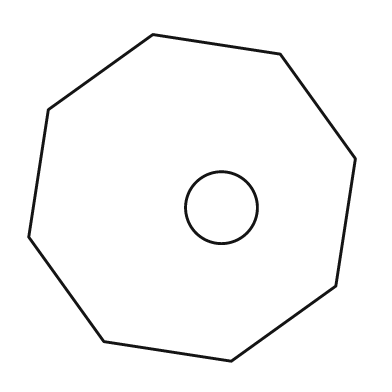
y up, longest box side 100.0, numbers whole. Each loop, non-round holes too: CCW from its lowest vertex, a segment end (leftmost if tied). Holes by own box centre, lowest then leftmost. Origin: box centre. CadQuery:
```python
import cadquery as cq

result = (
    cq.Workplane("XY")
    .moveTo(12.0, -50.0)
    .lineTo(44.0, -27.0)
    .lineTo(50.0, 12.0)
    .lineTo(27.0, 44.0)
    .lineTo(-12.0, 50.0)
    .lineTo(-44.0, 27.0)
    .lineTo(-50.0, -12.0)
    .lineTo(-27.0, -44.0)
    .close()
    .moveTo(9.0, -3.0)
    .circle(11.0)
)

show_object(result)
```